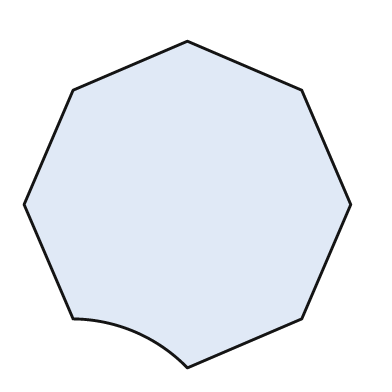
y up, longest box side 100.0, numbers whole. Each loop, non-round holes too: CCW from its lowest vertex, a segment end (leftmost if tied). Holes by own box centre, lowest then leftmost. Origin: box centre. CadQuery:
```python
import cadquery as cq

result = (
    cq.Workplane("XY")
    .moveTo(0.0, -50.0)
    .lineTo(35.0, -35.0)
    .lineTo(50.0, 0.0)
    .lineTo(35.0, 35.0)
    .lineTo(0.0, 50.0)
    .lineTo(-35.0, 35.0)
    .lineTo(-50.0, 0.0)
    .lineTo(-35.0, -35.0)
    .threePointArc((-16.0, -39.0), (0.0, -50.0))
    .close()
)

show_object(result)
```